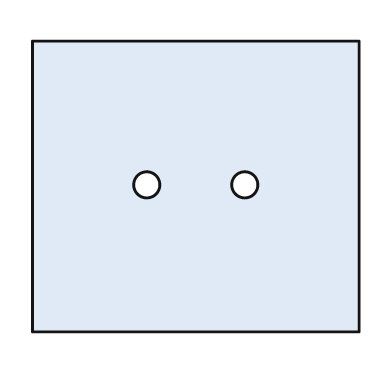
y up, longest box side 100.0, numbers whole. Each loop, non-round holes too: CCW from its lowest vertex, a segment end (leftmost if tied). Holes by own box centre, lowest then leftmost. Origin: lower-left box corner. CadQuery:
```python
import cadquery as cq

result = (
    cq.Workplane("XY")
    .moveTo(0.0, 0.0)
    .lineTo(100.0, 0.0)
    .lineTo(100.0, 89.0)
    .lineTo(0.0, 89.0)
    .close()
    .moveTo(35.0, 45.0)
    .circle(4.0)
    .moveTo(65.0, 45.0)
    .circle(4.0)
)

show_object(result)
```